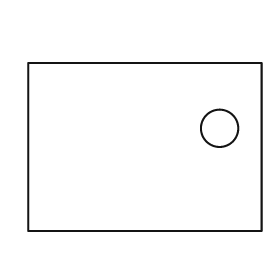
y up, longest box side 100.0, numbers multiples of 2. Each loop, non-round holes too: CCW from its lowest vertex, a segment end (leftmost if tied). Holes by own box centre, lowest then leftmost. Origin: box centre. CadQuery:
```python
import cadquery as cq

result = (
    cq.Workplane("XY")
    .moveTo(-50.0, -36.0)
    .lineTo(50.0, -36.0)
    .lineTo(50.0, 36.0)
    .lineTo(-50.0, 36.0)
    .close()
    .moveTo(32.0, 8.0)
    .circle(8.0)
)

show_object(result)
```